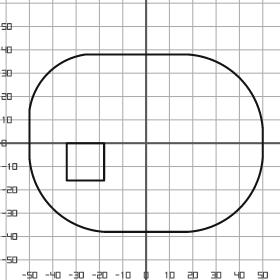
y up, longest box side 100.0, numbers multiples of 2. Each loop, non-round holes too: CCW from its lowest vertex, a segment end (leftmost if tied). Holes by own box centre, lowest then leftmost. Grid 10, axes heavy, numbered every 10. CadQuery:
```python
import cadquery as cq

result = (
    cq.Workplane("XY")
    .moveTo(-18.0, -38.0)
    .lineTo(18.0, -38.0)
    .threePointArc((40.0, -28.0), (50.0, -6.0))
    .lineTo(50.0, 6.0)
    .threePointArc((40.0, 28.0), (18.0, 38.0))
    .lineTo(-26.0, 38.0)
    .threePointArc((-42.0, 30.0), (-50.0, 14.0))
    .lineTo(-50.0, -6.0)
    .threePointArc((-40.0, -28.0), (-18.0, -38.0))
    .close()
    .moveTo(-34.0, -16.0)
    .lineTo(-18.0, -16.0)
    .lineTo(-18.0, 0.0)
    .lineTo(-34.0, 0.0)
    .close()
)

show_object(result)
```